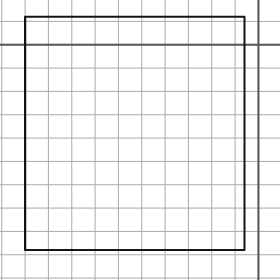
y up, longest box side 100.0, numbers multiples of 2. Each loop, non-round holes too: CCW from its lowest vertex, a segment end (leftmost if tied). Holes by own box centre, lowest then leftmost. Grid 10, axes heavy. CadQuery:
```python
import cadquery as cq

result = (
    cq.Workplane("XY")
    .moveTo(-100.0, -88.0)
    .lineTo(-6.0, -88.0)
    .lineTo(-6.0, 12.0)
    .lineTo(-100.0, 12.0)
    .close()
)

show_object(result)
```